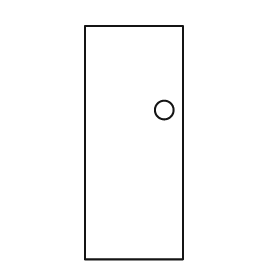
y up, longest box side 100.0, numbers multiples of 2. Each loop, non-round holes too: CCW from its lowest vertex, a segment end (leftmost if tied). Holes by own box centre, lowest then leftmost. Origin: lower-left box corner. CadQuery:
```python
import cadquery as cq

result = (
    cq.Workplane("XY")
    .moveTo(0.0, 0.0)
    .lineTo(42.0, 0.0)
    .lineTo(42.0, 100.0)
    .lineTo(0.0, 100.0)
    .close()
    .moveTo(34.0, 64.0)
    .circle(4.0)
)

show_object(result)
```